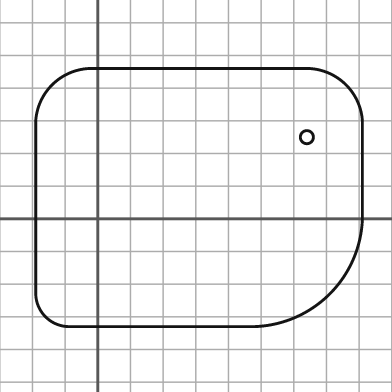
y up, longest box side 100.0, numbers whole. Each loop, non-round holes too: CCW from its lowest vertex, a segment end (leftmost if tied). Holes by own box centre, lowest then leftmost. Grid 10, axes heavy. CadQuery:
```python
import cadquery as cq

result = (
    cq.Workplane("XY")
    .moveTo(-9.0, -33.0)
    .lineTo(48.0, -33.0)
    .threePointArc((71.0, -23.0), (81.0, 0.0))
    .lineTo(81.0, 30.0)
    .threePointArc((76.0, 41.0), (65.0, 46.0))
    .lineTo(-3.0, 46.0)
    .threePointArc((-14.0, 41.0), (-19.0, 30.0))
    .lineTo(-19.0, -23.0)
    .threePointArc((-16.0, -30.0), (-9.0, -33.0))
    .close()
    .moveTo(64.0, 25.0)
    .circle(2.0)
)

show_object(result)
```